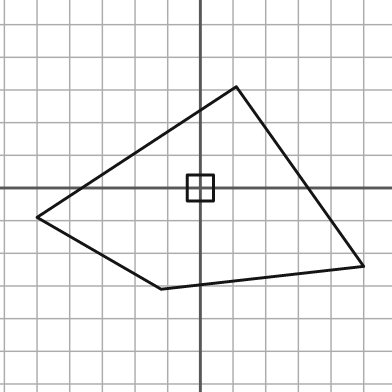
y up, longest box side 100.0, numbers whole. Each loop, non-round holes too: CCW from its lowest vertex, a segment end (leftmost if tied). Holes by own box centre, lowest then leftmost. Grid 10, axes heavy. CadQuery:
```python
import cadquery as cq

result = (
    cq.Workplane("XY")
    .moveTo(-12.0, -31.0)
    .lineTo(50.0, -24.0)
    .lineTo(11.0, 31.0)
    .lineTo(-50.0, -9.0)
    .close()
    .moveTo(-4.0, -4.0)
    .lineTo(4.0, -4.0)
    .lineTo(4.0, 4.0)
    .lineTo(-4.0, 4.0)
    .close()
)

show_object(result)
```